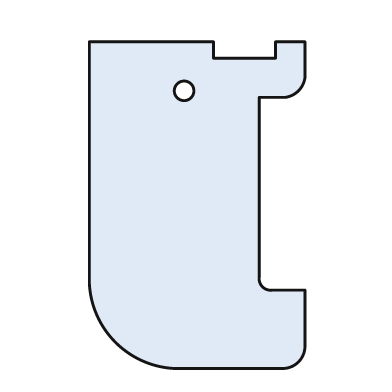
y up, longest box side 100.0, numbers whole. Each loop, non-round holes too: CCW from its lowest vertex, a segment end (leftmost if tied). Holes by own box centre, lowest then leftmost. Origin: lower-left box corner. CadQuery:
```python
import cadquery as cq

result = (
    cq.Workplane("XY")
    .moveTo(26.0, 0.0)
    .lineTo(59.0, 0.0)
    .threePointArc((64.0, 2.0), (66.0, 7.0))
    .lineTo(66.0, 24.0)
    .lineTo(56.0, 24.0)
    .threePointArc((53.0, 25.0), (52.0, 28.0))
    .lineTo(52.0, 83.0)
    .lineTo(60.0, 83.0)
    .threePointArc((64.0, 85.0), (66.0, 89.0))
    .lineTo(66.0, 100.0)
    .lineTo(57.0, 100.0)
    .lineTo(57.0, 95.0)
    .lineTo(38.0, 95.0)
    .lineTo(38.0, 100.0)
    .lineTo(0.0, 100.0)
    .lineTo(0.0, 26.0)
    .threePointArc((8.0, 8.0), (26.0, 0.0))
    .close()
    .moveTo(29.0, 85.0)
    .circle(3.0)
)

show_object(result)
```